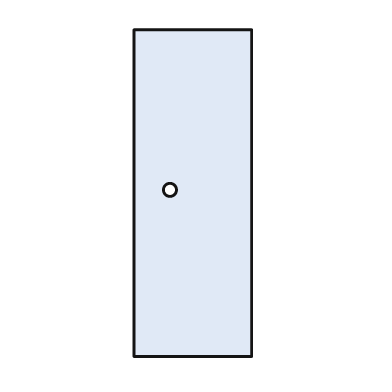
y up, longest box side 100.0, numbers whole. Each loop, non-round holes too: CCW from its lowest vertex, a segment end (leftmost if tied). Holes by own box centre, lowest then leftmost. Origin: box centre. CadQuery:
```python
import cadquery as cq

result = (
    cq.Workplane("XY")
    .moveTo(-18.0, -50.0)
    .lineTo(18.0, -50.0)
    .lineTo(18.0, 50.0)
    .lineTo(-18.0, 50.0)
    .close()
    .moveTo(-7.0, 1.0)
    .circle(2.0)
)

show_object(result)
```